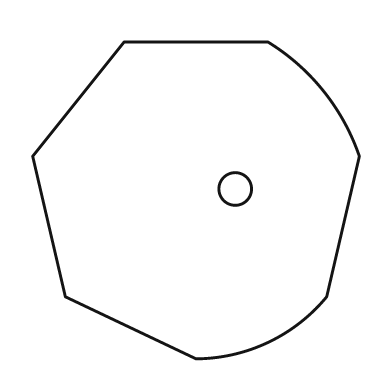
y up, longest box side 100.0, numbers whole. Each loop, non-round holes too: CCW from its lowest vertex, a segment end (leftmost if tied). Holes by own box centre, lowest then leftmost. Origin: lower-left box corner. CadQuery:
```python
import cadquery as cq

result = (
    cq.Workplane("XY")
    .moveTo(50.0, 0.0)
    .threePointArc((72.0, 5.0), (90.0, 19.0))
    .lineTo(100.0, 62.0)
    .threePointArc((89.0, 82.0), (72.0, 97.0))
    .lineTo(28.0, 97.0)
    .lineTo(0.0, 62.0)
    .lineTo(10.0, 19.0)
    .close()
    .moveTo(62.0, 52.0)
    .circle(5.0)
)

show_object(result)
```